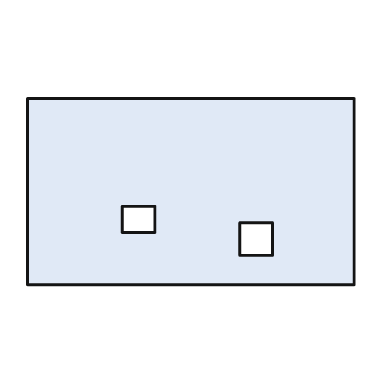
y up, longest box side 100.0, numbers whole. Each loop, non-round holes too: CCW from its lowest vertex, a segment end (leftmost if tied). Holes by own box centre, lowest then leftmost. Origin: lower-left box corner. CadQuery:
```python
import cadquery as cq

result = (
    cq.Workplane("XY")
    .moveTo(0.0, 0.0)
    .lineTo(100.0, 0.0)
    .lineTo(100.0, 57.0)
    .lineTo(0.0, 57.0)
    .close()
    .moveTo(65.0, 9.0)
    .lineTo(75.0, 9.0)
    .lineTo(75.0, 19.0)
    .lineTo(65.0, 19.0)
    .close()
    .moveTo(29.0, 16.0)
    .lineTo(39.0, 16.0)
    .lineTo(39.0, 24.0)
    .lineTo(29.0, 24.0)
    .close()
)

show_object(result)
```